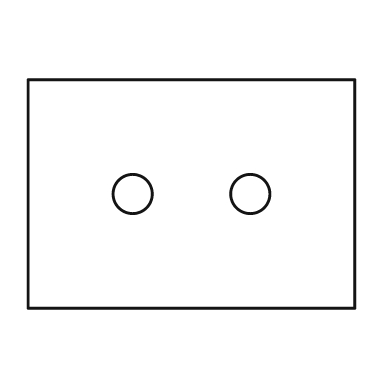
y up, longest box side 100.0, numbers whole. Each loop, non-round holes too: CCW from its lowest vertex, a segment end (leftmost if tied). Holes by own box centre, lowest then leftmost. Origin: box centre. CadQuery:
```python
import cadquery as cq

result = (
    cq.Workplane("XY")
    .moveTo(-50.0, -35.0)
    .lineTo(50.0, -35.0)
    .lineTo(50.0, 35.0)
    .lineTo(-50.0, 35.0)
    .close()
    .moveTo(-18.0, 0.0)
    .circle(6.0)
    .moveTo(18.0, 0.0)
    .circle(6.0)
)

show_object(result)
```